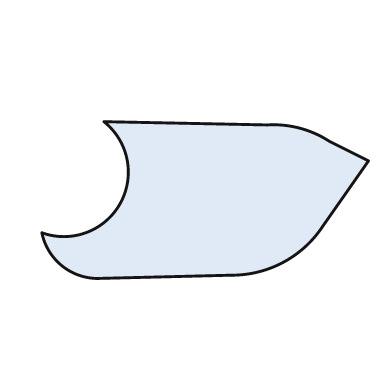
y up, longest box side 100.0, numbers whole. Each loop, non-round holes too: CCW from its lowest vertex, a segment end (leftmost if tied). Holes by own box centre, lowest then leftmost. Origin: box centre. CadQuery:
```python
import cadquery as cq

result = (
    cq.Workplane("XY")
    .moveTo(-33.0, -24.0)
    .lineTo(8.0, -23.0)
    .threePointArc((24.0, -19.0), (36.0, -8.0))
    .lineTo(50.0, 12.0)
    .lineTo(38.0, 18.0)
    .threePointArc((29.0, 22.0), (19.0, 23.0))
    .lineTo(-31.0, 24.0)
    .threePointArc((-26.0, -1.0), (-50.0, -10.0))
    .threePointArc((-44.0, -20.0), (-33.0, -24.0))
    .close()
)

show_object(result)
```